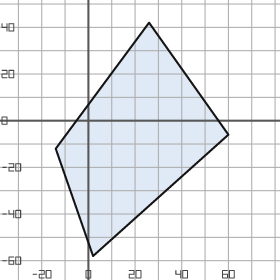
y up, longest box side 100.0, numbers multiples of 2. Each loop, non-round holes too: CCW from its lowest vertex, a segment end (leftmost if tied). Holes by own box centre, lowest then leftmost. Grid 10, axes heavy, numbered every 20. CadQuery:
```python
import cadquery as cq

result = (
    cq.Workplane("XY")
    .moveTo(2.0, -58.0)
    .lineTo(60.0, -6.0)
    .lineTo(26.0, 42.0)
    .lineTo(-14.0, -12.0)
    .close()
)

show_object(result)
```